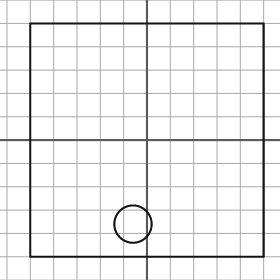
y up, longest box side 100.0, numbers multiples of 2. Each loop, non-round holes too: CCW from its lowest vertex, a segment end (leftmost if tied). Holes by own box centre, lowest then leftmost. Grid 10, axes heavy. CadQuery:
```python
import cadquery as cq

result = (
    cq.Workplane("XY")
    .moveTo(-50.0, -50.0)
    .lineTo(50.0, -50.0)
    .lineTo(50.0, 50.0)
    .lineTo(-50.0, 50.0)
    .close()
    .moveTo(-6.0, -36.0)
    .circle(8.0)
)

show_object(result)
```